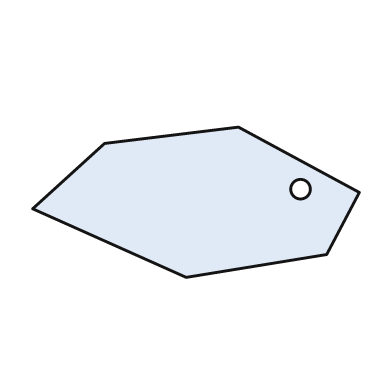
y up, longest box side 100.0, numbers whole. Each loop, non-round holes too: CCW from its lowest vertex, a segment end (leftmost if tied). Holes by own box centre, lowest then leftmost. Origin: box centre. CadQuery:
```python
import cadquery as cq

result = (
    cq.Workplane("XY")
    .moveTo(-3.0, -23.0)
    .lineTo(40.0, -16.0)
    .lineTo(50.0, 3.0)
    .lineTo(13.0, 23.0)
    .lineTo(-28.0, 18.0)
    .lineTo(-50.0, -2.0)
    .close()
    .moveTo(32.0, 4.0)
    .circle(3.0)
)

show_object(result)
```